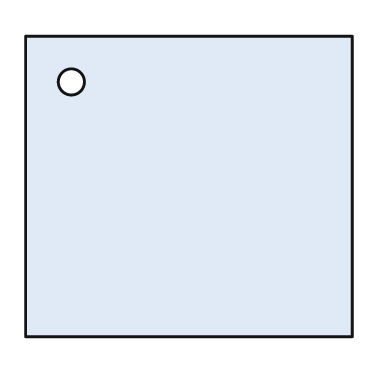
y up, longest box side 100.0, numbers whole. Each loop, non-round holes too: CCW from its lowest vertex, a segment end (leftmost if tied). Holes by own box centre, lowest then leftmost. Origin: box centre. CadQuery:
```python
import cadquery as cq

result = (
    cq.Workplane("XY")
    .moveTo(-50.0, -46.0)
    .lineTo(50.0, -46.0)
    .lineTo(50.0, 46.0)
    .lineTo(-50.0, 46.0)
    .close()
    .moveTo(-36.0, 32.0)
    .circle(4.0)
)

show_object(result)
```